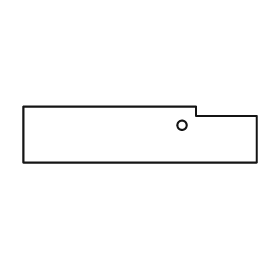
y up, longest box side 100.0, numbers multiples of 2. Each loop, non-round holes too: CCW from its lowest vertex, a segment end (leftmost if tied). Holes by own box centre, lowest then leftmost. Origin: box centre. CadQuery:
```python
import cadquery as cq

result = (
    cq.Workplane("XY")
    .moveTo(-50.0, -12.0)
    .lineTo(50.0, -12.0)
    .lineTo(50.0, 8.0)
    .lineTo(24.0, 8.0)
    .lineTo(24.0, 12.0)
    .lineTo(-50.0, 12.0)
    .close()
    .moveTo(18.0, 4.0)
    .circle(2.0)
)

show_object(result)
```